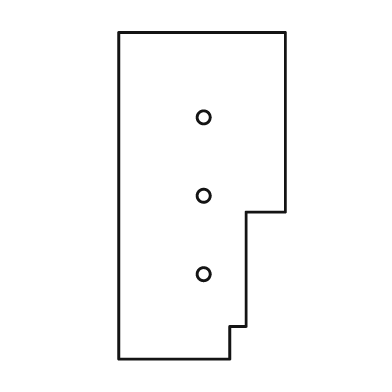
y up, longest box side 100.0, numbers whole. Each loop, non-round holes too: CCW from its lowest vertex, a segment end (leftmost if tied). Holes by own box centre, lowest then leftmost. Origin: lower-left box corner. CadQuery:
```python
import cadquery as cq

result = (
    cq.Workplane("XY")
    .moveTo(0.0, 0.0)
    .lineTo(34.0, 0.0)
    .lineTo(34.0, 10.0)
    .lineTo(39.0, 10.0)
    .lineTo(39.0, 45.0)
    .lineTo(51.0, 45.0)
    .lineTo(51.0, 100.0)
    .lineTo(0.0, 100.0)
    .close()
    .moveTo(26.0, 26.0)
    .circle(2.0)
    .moveTo(26.0, 50.0)
    .circle(2.0)
    .moveTo(26.0, 74.0)
    .circle(2.0)
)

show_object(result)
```